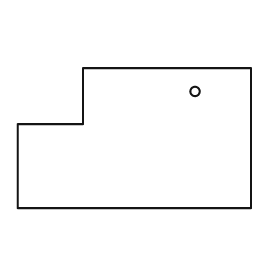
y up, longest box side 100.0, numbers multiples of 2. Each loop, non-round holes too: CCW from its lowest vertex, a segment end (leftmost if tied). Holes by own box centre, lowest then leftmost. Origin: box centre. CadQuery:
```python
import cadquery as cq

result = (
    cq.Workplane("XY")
    .moveTo(-50.0, -30.0)
    .lineTo(50.0, -30.0)
    .lineTo(50.0, 30.0)
    .lineTo(-22.0, 30.0)
    .lineTo(-22.0, 6.0)
    .lineTo(-50.0, 6.0)
    .close()
    .moveTo(26.0, 20.0)
    .circle(2.0)
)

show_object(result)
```